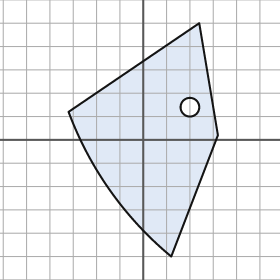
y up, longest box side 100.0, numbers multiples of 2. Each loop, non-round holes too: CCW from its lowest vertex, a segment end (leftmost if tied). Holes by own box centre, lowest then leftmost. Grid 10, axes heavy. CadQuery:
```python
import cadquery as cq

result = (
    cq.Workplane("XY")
    .moveTo(12.0, -50.0)
    .lineTo(32.0, 2.0)
    .lineTo(24.0, 50.0)
    .lineTo(-32.0, 12.0)
    .threePointArc((-14.0, -22.0), (12.0, -50.0))
    .close()
    .moveTo(20.0, 14.0)
    .circle(4.0)
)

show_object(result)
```